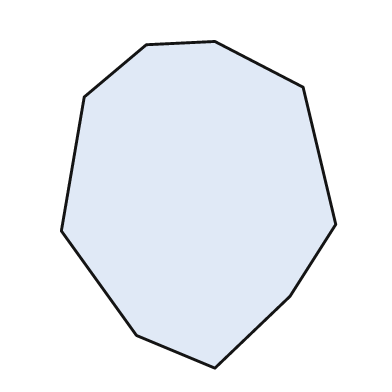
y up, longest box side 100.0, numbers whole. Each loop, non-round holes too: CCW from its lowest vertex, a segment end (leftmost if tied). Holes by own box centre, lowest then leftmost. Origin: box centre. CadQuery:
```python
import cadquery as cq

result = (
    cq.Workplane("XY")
    .moveTo(5.0, -50.0)
    .lineTo(28.0, -28.0)
    .lineTo(42.0, -6.0)
    .lineTo(32.0, 36.0)
    .lineTo(5.0, 50.0)
    .lineTo(-16.0, 49.0)
    .lineTo(-35.0, 33.0)
    .lineTo(-42.0, -8.0)
    .lineTo(-19.0, -40.0)
    .close()
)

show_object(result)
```